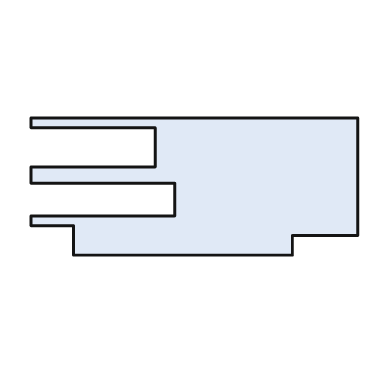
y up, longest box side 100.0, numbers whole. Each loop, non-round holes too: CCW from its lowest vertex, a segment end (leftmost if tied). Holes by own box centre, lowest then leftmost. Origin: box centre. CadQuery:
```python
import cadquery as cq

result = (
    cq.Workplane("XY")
    .moveTo(-37.0, -21.0)
    .lineTo(30.0, -21.0)
    .lineTo(30.0, -15.0)
    .lineTo(50.0, -15.0)
    .lineTo(50.0, 21.0)
    .lineTo(-50.0, 21.0)
    .lineTo(-50.0, 18.0)
    .lineTo(-12.0, 18.0)
    .lineTo(-12.0, 6.0)
    .lineTo(-50.0, 6.0)
    .lineTo(-50.0, 1.0)
    .lineTo(-6.0, 1.0)
    .lineTo(-6.0, -9.0)
    .lineTo(-50.0, -9.0)
    .lineTo(-50.0, -12.0)
    .lineTo(-37.0, -12.0)
    .close()
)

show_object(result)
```